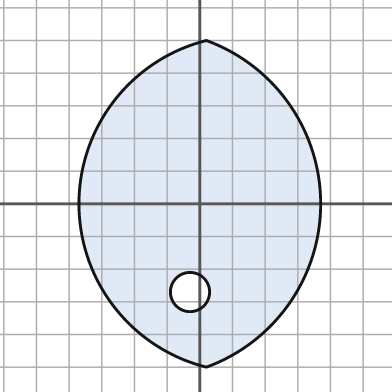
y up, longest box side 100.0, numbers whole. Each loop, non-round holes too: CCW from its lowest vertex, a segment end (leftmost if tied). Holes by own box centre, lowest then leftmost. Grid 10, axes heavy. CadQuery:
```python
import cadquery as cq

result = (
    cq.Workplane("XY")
    .moveTo(2.0, -50.0)
    .threePointArc((37.0, 0.0), (2.0, 50.0))
    .threePointArc((-37.0, 0.0), (2.0, -50.0))
    .close()
    .moveTo(-3.0, -27.0)
    .circle(6.0)
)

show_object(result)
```